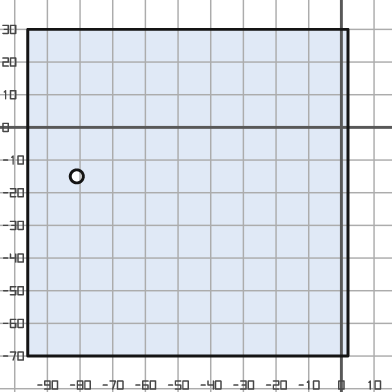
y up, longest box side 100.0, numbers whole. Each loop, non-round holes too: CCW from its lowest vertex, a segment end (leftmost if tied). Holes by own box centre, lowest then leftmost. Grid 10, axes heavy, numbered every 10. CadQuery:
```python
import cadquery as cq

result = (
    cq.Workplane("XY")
    .moveTo(-96.0, -70.0)
    .lineTo(2.0, -70.0)
    .lineTo(2.0, 30.0)
    .lineTo(-96.0, 30.0)
    .close()
    .moveTo(-81.0, -15.0)
    .circle(2.0)
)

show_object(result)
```